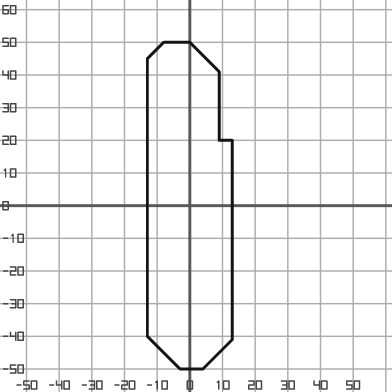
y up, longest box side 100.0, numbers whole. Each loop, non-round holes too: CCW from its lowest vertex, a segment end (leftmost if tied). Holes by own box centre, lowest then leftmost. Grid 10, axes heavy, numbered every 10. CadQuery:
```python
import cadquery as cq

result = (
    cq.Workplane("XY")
    .moveTo(-3.0, -50.0)
    .lineTo(4.0, -50.0)
    .lineTo(13.0, -41.0)
    .lineTo(13.0, 20.0)
    .lineTo(9.0, 20.0)
    .lineTo(9.0, 41.0)
    .lineTo(0.0, 50.0)
    .lineTo(-8.0, 50.0)
    .lineTo(-13.0, 45.0)
    .lineTo(-13.0, -40.0)
    .close()
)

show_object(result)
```